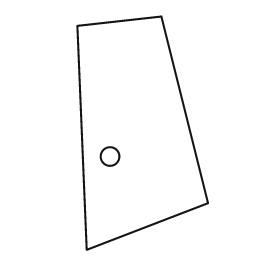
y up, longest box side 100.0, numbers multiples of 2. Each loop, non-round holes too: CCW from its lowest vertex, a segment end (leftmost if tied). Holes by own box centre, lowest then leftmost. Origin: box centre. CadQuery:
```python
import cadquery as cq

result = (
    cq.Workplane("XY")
    .moveTo(-24.0, -50.0)
    .lineTo(28.0, -30.0)
    .lineTo(8.0, 50.0)
    .lineTo(-28.0, 46.0)
    .close()
    .moveTo(-14.0, -10.0)
    .circle(4.0)
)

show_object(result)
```